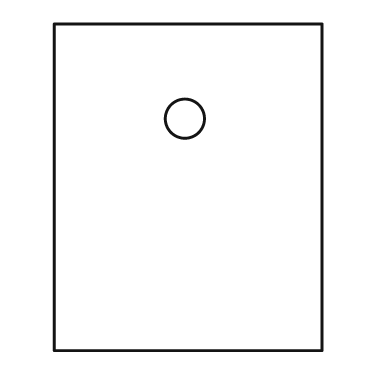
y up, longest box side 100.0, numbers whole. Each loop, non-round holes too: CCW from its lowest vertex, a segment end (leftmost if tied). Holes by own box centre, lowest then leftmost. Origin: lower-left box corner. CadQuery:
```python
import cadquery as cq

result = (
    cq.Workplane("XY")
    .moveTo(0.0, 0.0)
    .lineTo(82.0, 0.0)
    .lineTo(82.0, 100.0)
    .lineTo(0.0, 100.0)
    .close()
    .moveTo(40.0, 71.0)
    .circle(6.0)
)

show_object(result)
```